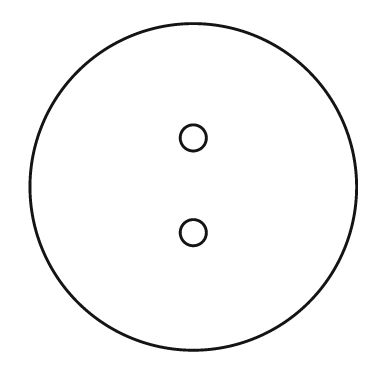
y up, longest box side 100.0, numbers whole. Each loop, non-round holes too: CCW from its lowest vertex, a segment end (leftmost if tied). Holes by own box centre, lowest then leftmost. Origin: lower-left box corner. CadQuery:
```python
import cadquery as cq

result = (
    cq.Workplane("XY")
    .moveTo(50.0, 50.0)
    .circle(50.0)
    .moveTo(50.0, 36.0)
    .circle(4.0)
    .moveTo(50.0, 65.0)
    .circle(4.0)
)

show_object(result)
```